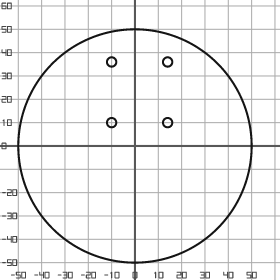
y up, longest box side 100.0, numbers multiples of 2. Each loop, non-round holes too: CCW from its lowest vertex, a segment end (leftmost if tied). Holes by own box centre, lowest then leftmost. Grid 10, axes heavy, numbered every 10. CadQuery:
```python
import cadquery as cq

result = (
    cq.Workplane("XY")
    .moveTo(0.0, 0.0)
    .circle(50.0)
    .moveTo(-10.0, 10.0)
    .circle(2.0)
    .moveTo(14.0, 10.0)
    .circle(2.0)
    .moveTo(-10.0, 36.0)
    .circle(2.0)
    .moveTo(14.0, 36.0)
    .circle(2.0)
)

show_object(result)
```